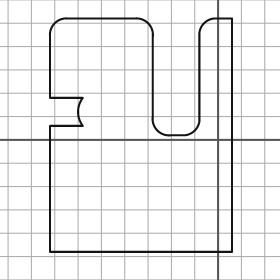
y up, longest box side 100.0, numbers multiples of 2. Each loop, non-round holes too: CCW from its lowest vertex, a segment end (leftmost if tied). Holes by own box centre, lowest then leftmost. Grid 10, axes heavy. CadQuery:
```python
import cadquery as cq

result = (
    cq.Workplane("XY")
    .moveTo(-72.0, -48.0)
    .lineTo(6.0, -48.0)
    .lineTo(6.0, 52.0)
    .lineTo(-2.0, 52.0)
    .threePointArc((-6.0, 50.0), (-8.0, 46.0))
    .lineTo(-8.0, 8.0)
    .threePointArc((-10.0, 4.0), (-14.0, 2.0))
    .lineTo(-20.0, 2.0)
    .threePointArc((-26.0, 4.0), (-28.0, 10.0))
    .lineTo(-28.0, 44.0)
    .threePointArc((-30.0, 50.0), (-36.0, 52.0))
    .lineTo(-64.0, 52.0)
    .threePointArc((-70.0, 50.0), (-72.0, 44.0))
    .lineTo(-72.0, 18.0)
    .lineTo(-58.0, 18.0)
    .threePointArc((-60.0, 12.0), (-58.0, 6.0))
    .lineTo(-72.0, 6.0)
    .close()
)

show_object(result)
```